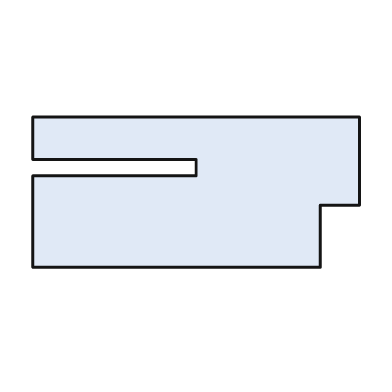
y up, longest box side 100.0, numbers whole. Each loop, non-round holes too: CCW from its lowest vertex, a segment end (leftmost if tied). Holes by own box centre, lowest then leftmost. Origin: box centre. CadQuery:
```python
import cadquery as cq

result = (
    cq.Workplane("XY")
    .moveTo(-50.0, -23.0)
    .lineTo(38.0, -23.0)
    .lineTo(38.0, -4.0)
    .lineTo(50.0, -4.0)
    .lineTo(50.0, 23.0)
    .lineTo(-50.0, 23.0)
    .lineTo(-50.0, 10.0)
    .lineTo(0.0, 10.0)
    .lineTo(0.0, 5.0)
    .lineTo(-50.0, 5.0)
    .close()
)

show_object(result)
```